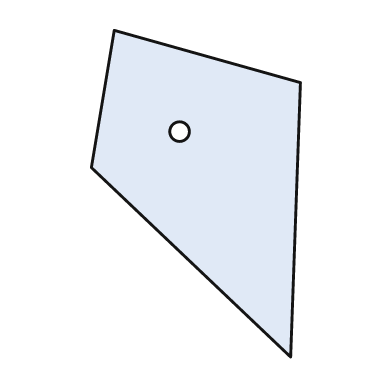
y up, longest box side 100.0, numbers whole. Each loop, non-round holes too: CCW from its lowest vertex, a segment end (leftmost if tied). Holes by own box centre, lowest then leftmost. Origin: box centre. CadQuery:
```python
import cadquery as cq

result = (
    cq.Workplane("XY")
    .moveTo(29.0, -50.0)
    .lineTo(32.0, 34.0)
    .lineTo(-25.0, 50.0)
    .lineTo(-32.0, 8.0)
    .close()
    .moveTo(-5.0, 19.0)
    .circle(3.0)
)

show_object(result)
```